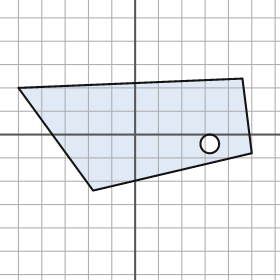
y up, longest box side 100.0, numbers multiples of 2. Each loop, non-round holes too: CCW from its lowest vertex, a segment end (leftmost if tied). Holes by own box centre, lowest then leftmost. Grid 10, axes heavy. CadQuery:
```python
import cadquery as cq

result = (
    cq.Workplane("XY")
    .moveTo(-18.0, -24.0)
    .lineTo(50.0, -8.0)
    .lineTo(46.0, 24.0)
    .lineTo(-50.0, 20.0)
    .close()
    .moveTo(32.0, -4.0)
    .circle(4.0)
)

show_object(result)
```